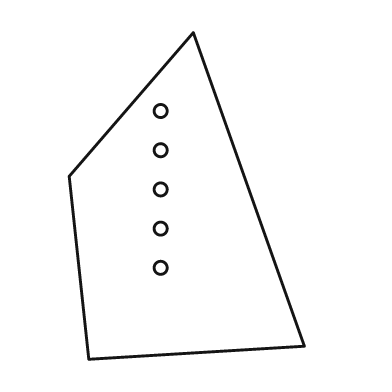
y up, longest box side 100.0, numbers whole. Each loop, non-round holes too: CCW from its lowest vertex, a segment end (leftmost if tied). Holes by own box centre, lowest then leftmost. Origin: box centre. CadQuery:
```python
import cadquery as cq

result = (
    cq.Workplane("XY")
    .moveTo(-30.0, -50.0)
    .lineTo(36.0, -46.0)
    .lineTo(2.0, 50.0)
    .lineTo(-36.0, 6.0)
    .close()
    .moveTo(-8.0, -22.0)
    .circle(2.0)
    .moveTo(-8.0, -10.0)
    .circle(2.0)
    .moveTo(-8.0, 2.0)
    .circle(2.0)
    .moveTo(-8.0, 14.0)
    .circle(2.0)
    .moveTo(-8.0, 26.0)
    .circle(2.0)
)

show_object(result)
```